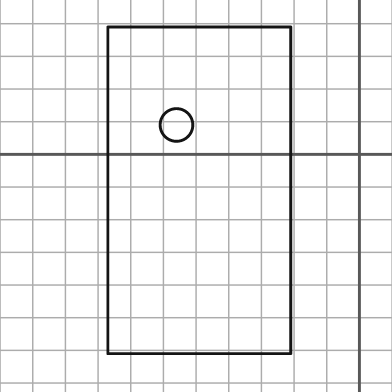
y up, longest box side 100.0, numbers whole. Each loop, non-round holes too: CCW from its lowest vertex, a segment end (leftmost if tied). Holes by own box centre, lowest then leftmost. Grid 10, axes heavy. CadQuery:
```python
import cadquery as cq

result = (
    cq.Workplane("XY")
    .moveTo(-77.0, -61.0)
    .lineTo(-21.0, -61.0)
    .lineTo(-21.0, 39.0)
    .lineTo(-77.0, 39.0)
    .close()
    .moveTo(-56.0, 9.0)
    .circle(5.0)
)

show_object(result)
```